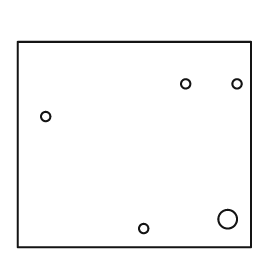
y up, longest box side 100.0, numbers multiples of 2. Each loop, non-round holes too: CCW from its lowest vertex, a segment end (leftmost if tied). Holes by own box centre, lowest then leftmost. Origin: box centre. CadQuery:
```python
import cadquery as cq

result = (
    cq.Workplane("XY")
    .moveTo(-50.0, -44.0)
    .lineTo(50.0, -44.0)
    .lineTo(50.0, 44.0)
    .lineTo(-50.0, 44.0)
    .close()
    .moveTo(4.0, -36.0)
    .circle(2.0)
    .moveTo(40.0, -32.0)
    .circle(4.0)
    .moveTo(-38.0, 12.0)
    .circle(2.0)
    .moveTo(22.0, 26.0)
    .circle(2.0)
    .moveTo(44.0, 26.0)
    .circle(2.0)
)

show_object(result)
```